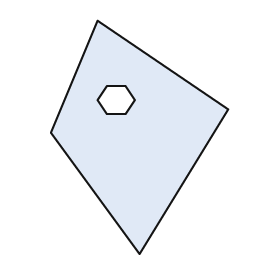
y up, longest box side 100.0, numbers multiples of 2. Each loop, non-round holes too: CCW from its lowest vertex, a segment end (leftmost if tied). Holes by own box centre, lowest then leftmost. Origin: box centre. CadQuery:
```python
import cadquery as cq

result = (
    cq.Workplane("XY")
    .moveTo(0.0, -50.0)
    .lineTo(38.0, 12.0)
    .lineTo(-18.0, 50.0)
    .lineTo(-38.0, 2.0)
    .close()
    .moveTo(-14.0, 10.0)
    .lineTo(-6.0, 10.0)
    .lineTo(-2.0, 16.0)
    .lineTo(-6.0, 22.0)
    .lineTo(-14.0, 22.0)
    .lineTo(-18.0, 16.0)
    .close()
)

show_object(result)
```